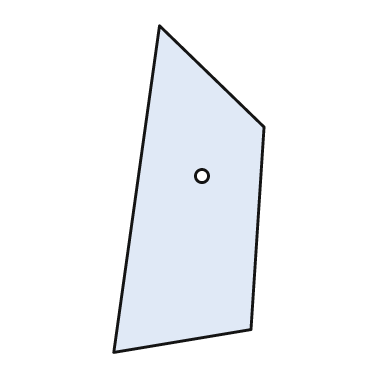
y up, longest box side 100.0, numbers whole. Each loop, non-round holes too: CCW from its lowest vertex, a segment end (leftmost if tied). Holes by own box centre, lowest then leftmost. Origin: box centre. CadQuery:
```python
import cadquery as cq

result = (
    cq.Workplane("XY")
    .moveTo(-23.0, -50.0)
    .lineTo(19.0, -43.0)
    .lineTo(23.0, 19.0)
    .lineTo(-9.0, 50.0)
    .close()
    .moveTo(4.0, 4.0)
    .circle(2.0)
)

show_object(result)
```